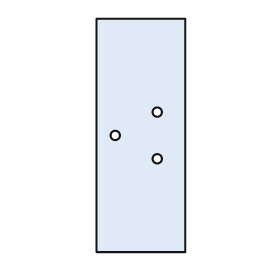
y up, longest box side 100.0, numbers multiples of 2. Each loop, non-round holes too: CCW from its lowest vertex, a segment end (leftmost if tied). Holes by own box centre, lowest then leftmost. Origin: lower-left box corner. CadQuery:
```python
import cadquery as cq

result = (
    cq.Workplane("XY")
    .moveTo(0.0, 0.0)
    .lineTo(38.0, 0.0)
    .lineTo(38.0, 100.0)
    .lineTo(0.0, 100.0)
    .close()
    .moveTo(26.0, 40.0)
    .circle(2.0)
    .moveTo(8.0, 50.0)
    .circle(2.0)
    .moveTo(26.0, 60.0)
    .circle(2.0)
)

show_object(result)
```